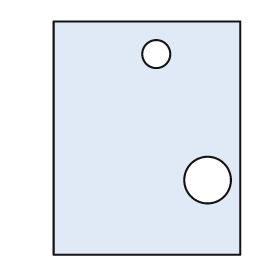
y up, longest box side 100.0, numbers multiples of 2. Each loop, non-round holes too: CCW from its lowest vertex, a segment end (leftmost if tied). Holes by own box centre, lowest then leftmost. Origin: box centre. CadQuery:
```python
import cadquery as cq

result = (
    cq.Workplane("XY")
    .moveTo(-40.0, -50.0)
    .lineTo(40.0, -50.0)
    .lineTo(40.0, 50.0)
    .lineTo(-40.0, 50.0)
    .close()
    .moveTo(26.0, -18.0)
    .circle(10.0)
    .moveTo(4.0, 36.0)
    .circle(6.0)
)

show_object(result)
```